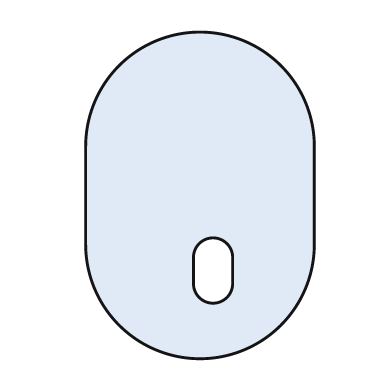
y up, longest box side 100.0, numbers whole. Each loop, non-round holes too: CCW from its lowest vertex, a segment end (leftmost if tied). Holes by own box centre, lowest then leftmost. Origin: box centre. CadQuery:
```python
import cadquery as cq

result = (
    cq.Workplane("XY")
    .moveTo(-35.0, -15.0)
    .threePointArc((0.0, -50.0), (35.0, -15.0))
    .lineTo(35.0, 15.0)
    .threePointArc((0.0, 50.0), (-35.0, 15.0))
    .close()
    .moveTo(-2.0, -27.0)
    .threePointArc((4.0, -33.0), (10.0, -27.0))
    .lineTo(10.0, -19.0)
    .threePointArc((4.0, -13.0), (-2.0, -19.0))
    .close()
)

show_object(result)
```